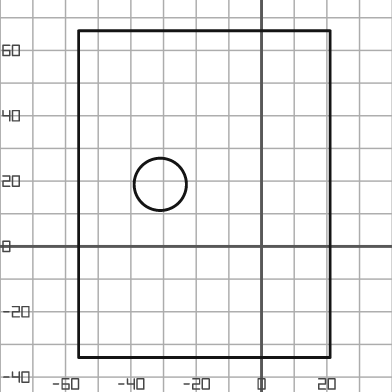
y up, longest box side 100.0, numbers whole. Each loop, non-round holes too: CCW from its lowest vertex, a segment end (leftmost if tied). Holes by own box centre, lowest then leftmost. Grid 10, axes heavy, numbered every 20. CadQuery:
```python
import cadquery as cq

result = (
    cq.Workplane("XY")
    .moveTo(-56.0, -34.0)
    .lineTo(21.0, -34.0)
    .lineTo(21.0, 66.0)
    .lineTo(-56.0, 66.0)
    .close()
    .moveTo(-31.0, 19.0)
    .circle(8.0)
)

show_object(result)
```